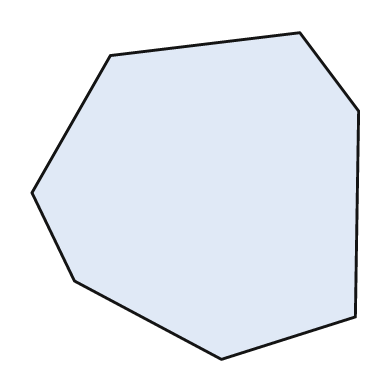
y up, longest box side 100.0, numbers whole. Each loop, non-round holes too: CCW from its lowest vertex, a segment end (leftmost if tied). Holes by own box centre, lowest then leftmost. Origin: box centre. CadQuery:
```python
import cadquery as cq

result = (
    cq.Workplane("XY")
    .moveTo(8.0, -50.0)
    .lineTo(49.0, -37.0)
    .lineTo(50.0, 26.0)
    .lineTo(32.0, 50.0)
    .lineTo(-26.0, 43.0)
    .lineTo(-50.0, 1.0)
    .lineTo(-37.0, -26.0)
    .close()
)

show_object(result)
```